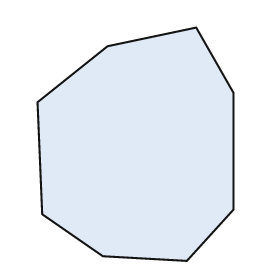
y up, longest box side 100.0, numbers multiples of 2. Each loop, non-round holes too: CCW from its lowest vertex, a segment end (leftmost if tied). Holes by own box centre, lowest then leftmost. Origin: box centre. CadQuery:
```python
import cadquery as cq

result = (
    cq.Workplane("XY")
    .moveTo(22.0, -50.0)
    .lineTo(42.0, -28.0)
    .lineTo(42.0, 22.0)
    .lineTo(26.0, 50.0)
    .lineTo(-12.0, 42.0)
    .lineTo(-42.0, 18.0)
    .lineTo(-40.0, -30.0)
    .lineTo(-14.0, -48.0)
    .close()
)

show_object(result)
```